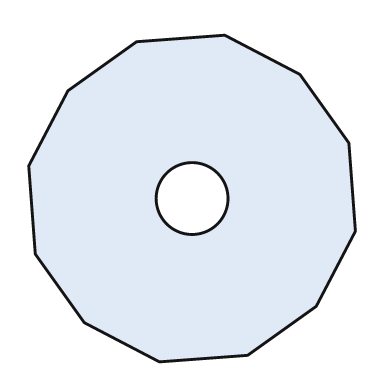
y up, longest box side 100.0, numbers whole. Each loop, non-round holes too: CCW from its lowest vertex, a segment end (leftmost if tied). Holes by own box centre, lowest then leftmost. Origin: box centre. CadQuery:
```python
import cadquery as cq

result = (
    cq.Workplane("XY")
    .moveTo(-10.0, -50.0)
    .lineTo(17.0, -48.0)
    .lineTo(38.0, -33.0)
    .lineTo(50.0, -10.0)
    .lineTo(48.0, 17.0)
    .lineTo(33.0, 38.0)
    .lineTo(10.0, 50.0)
    .lineTo(-17.0, 48.0)
    .lineTo(-38.0, 33.0)
    .lineTo(-50.0, 10.0)
    .lineTo(-48.0, -17.0)
    .lineTo(-33.0, -38.0)
    .close()
    .moveTo(0.0, 0.0)
    .circle(11.0)
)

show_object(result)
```